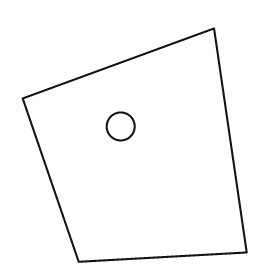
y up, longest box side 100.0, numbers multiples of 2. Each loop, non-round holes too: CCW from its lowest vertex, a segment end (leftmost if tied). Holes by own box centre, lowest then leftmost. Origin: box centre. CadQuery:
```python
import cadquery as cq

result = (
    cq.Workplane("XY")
    .moveTo(-24.0, -50.0)
    .lineTo(48.0, -46.0)
    .lineTo(34.0, 50.0)
    .lineTo(-48.0, 20.0)
    .close()
    .moveTo(-6.0, 8.0)
    .circle(6.0)
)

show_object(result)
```